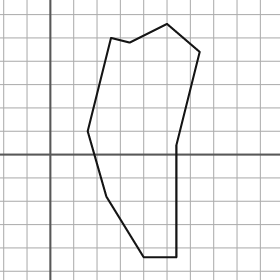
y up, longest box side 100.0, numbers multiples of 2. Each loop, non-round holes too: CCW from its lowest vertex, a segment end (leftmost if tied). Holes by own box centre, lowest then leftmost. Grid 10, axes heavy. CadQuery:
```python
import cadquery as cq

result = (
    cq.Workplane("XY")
    .moveTo(40.0, -44.0)
    .lineTo(54.0, -44.0)
    .lineTo(54.0, 4.0)
    .lineTo(64.0, 44.0)
    .lineTo(50.0, 56.0)
    .lineTo(34.0, 48.0)
    .lineTo(26.0, 50.0)
    .lineTo(16.0, 10.0)
    .lineTo(24.0, -18.0)
    .close()
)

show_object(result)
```